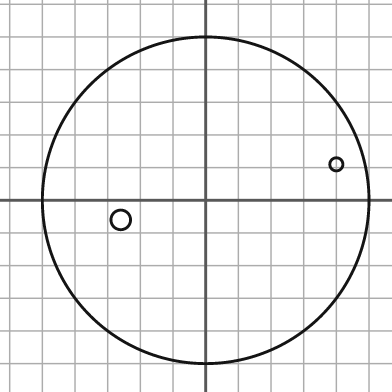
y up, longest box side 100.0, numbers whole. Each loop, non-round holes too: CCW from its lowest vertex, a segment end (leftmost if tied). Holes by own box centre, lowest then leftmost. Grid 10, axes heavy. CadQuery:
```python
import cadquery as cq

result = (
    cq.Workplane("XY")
    .moveTo(0.0, 0.0)
    .circle(50.0)
    .moveTo(-26.0, -6.0)
    .circle(3.0)
    .moveTo(40.0, 11.0)
    .circle(2.0)
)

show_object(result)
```